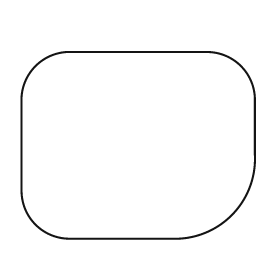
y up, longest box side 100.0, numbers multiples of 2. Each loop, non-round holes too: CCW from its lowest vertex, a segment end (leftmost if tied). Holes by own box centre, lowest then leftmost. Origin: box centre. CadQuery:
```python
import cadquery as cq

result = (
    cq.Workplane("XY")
    .moveTo(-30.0, -40.0)
    .lineTo(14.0, -40.0)
    .threePointArc((40.0, -30.0), (50.0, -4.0))
    .lineTo(50.0, 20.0)
    .threePointArc((44.0, 34.0), (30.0, 40.0))
    .lineTo(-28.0, 40.0)
    .threePointArc((-44.0, 34.0), (-50.0, 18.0))
    .lineTo(-50.0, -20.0)
    .threePointArc((-44.0, -34.0), (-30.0, -40.0))
    .close()
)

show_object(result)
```